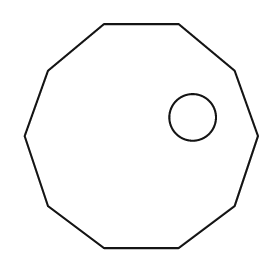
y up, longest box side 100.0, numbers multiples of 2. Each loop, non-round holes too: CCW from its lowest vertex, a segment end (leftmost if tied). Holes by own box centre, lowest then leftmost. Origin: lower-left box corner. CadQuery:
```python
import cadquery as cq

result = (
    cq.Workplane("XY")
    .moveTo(34.0, 0.0)
    .lineTo(66.0, 0.0)
    .lineTo(90.0, 18.0)
    .lineTo(100.0, 48.0)
    .lineTo(90.0, 76.0)
    .lineTo(66.0, 96.0)
    .lineTo(34.0, 96.0)
    .lineTo(10.0, 76.0)
    .lineTo(0.0, 48.0)
    .lineTo(10.0, 18.0)
    .close()
    .moveTo(72.0, 56.0)
    .circle(10.0)
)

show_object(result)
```